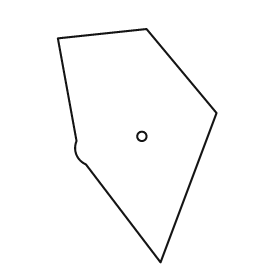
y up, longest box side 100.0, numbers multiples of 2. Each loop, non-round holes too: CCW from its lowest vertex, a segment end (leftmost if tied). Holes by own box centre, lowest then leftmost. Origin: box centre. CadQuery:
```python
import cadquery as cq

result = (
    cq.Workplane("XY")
    .moveTo(10.0, -50.0)
    .lineTo(34.0, 14.0)
    .lineTo(4.0, 50.0)
    .lineTo(-34.0, 46.0)
    .lineTo(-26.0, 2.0)
    .threePointArc((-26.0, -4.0), (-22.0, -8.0))
    .close()
    .moveTo(2.0, 4.0)
    .circle(2.0)
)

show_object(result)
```